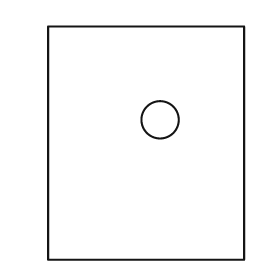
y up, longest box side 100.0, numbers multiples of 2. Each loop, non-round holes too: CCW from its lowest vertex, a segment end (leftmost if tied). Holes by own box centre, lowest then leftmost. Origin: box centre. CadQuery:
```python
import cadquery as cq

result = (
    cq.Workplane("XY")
    .moveTo(-42.0, -50.0)
    .lineTo(42.0, -50.0)
    .lineTo(42.0, 50.0)
    .lineTo(-42.0, 50.0)
    .close()
    .moveTo(6.0, 10.0)
    .circle(8.0)
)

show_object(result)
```